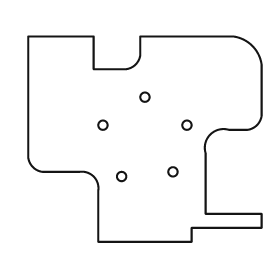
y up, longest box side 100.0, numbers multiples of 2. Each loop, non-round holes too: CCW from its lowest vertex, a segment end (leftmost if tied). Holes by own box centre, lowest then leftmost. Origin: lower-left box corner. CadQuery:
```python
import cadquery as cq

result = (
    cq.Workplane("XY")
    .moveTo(30.0, 0.0)
    .lineTo(70.0, 0.0)
    .lineTo(70.0, 6.0)
    .lineTo(100.0, 6.0)
    .lineTo(100.0, 12.0)
    .lineTo(76.0, 12.0)
    .lineTo(76.0, 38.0)
    .threePointArc((78.0, 46.0), (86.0, 48.0))
    .lineTo(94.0, 48.0)
    .threePointArc((98.0, 50.0), (100.0, 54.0))
    .lineTo(100.0, 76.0)
    .threePointArc((96.0, 84.0), (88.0, 88.0))
    .lineTo(48.0, 88.0)
    .lineTo(48.0, 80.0)
    .threePointArc((46.0, 76.0), (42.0, 74.0))
    .lineTo(28.0, 74.0)
    .lineTo(28.0, 88.0)
    .lineTo(0.0, 88.0)
    .lineTo(0.0, 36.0)
    .threePointArc((2.0, 32.0), (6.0, 30.0))
    .lineTo(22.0, 30.0)
    .threePointArc((28.0, 28.0), (30.0, 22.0))
    .close()
    .moveTo(40.0, 28.0)
    .circle(2.0)
    .moveTo(62.0, 30.0)
    .circle(2.0)
    .moveTo(32.0, 50.0)
    .circle(2.0)
    .moveTo(68.0, 50.0)
    .circle(2.0)
    .moveTo(50.0, 62.0)
    .circle(2.0)
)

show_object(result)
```